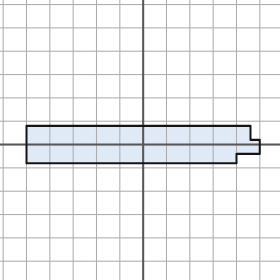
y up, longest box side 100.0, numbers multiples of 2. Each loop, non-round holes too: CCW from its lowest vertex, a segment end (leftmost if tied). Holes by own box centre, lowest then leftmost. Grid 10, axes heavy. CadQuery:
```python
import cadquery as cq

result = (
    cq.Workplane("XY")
    .moveTo(-50.0, -8.0)
    .lineTo(40.0, -8.0)
    .lineTo(40.0, -4.0)
    .lineTo(50.0, -4.0)
    .lineTo(50.0, 2.0)
    .lineTo(46.0, 2.0)
    .lineTo(46.0, 8.0)
    .lineTo(-50.0, 8.0)
    .close()
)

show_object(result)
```